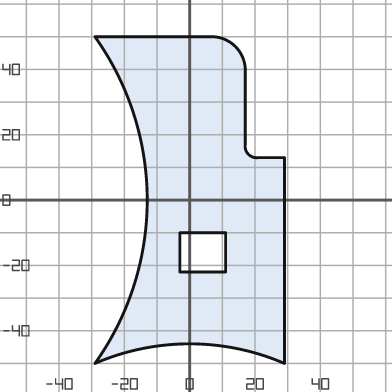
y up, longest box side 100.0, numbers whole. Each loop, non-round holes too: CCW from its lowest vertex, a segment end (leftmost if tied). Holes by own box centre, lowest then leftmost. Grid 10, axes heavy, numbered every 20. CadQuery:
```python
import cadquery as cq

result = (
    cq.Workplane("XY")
    .moveTo(-29.0, -50.0)
    .threePointArc((0.0, -44.0), (29.0, -50.0))
    .lineTo(29.0, 13.0)
    .lineTo(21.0, 13.0)
    .threePointArc((18.0, 14.0), (17.0, 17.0))
    .lineTo(17.0, 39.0)
    .threePointArc((14.0, 47.0), (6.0, 50.0))
    .lineTo(-29.0, 50.0)
    .threePointArc((-13.0, 0.0), (-29.0, -50.0))
    .close()
    .moveTo(-3.0, -22.0)
    .lineTo(11.0, -22.0)
    .lineTo(11.0, -10.0)
    .lineTo(-3.0, -10.0)
    .close()
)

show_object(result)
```